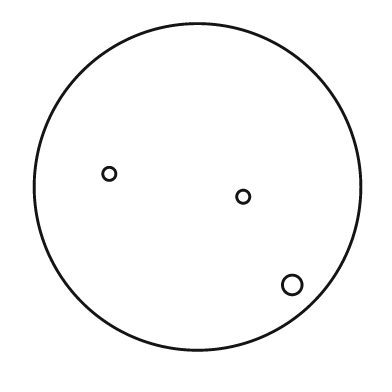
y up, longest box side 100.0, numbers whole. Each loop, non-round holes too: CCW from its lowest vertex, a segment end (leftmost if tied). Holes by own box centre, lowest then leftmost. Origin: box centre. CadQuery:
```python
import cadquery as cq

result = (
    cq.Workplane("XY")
    .moveTo(0.0, 0.0)
    .circle(50.0)
    .moveTo(29.0, -30.0)
    .circle(3.0)
    .moveTo(14.0, -3.0)
    .circle(2.0)
    .moveTo(-27.0, 4.0)
    .circle(2.0)
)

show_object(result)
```